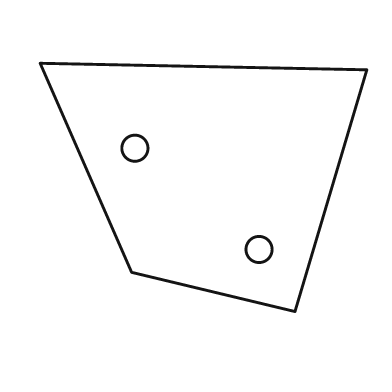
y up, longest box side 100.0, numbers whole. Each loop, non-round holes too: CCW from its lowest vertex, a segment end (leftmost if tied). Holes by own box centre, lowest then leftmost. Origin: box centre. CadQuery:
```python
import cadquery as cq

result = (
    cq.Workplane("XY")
    .moveTo(28.0, -38.0)
    .lineTo(50.0, 36.0)
    .lineTo(-50.0, 38.0)
    .lineTo(-22.0, -26.0)
    .close()
    .moveTo(17.0, -19.0)
    .circle(4.0)
    .moveTo(-21.0, 12.0)
    .circle(4.0)
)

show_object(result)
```